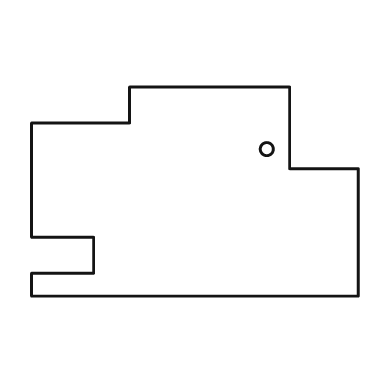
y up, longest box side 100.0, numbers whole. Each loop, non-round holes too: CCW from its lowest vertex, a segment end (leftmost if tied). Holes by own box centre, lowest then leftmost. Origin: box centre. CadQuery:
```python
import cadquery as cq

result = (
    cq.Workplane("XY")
    .moveTo(-50.0, -32.0)
    .lineTo(50.0, -32.0)
    .lineTo(50.0, 7.0)
    .lineTo(29.0, 7.0)
    .lineTo(29.0, 32.0)
    .lineTo(-20.0, 32.0)
    .lineTo(-20.0, 21.0)
    .lineTo(-50.0, 21.0)
    .lineTo(-50.0, -14.0)
    .lineTo(-31.0, -14.0)
    .lineTo(-31.0, -25.0)
    .lineTo(-50.0, -25.0)
    .close()
    .moveTo(22.0, 13.0)
    .circle(2.0)
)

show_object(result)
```